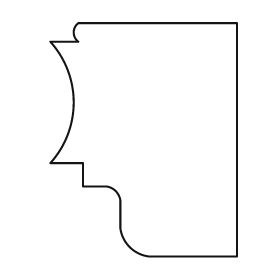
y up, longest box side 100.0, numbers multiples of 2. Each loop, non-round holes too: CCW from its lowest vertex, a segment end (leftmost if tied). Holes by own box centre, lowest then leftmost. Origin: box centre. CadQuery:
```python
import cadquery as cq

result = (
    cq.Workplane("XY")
    .moveTo(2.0, -50.0)
    .lineTo(40.0, -50.0)
    .lineTo(40.0, 50.0)
    .lineTo(-28.0, 50.0)
    .threePointArc((-30.0, 46.0), (-28.0, 42.0))
    .lineTo(-40.0, 42.0)
    .threePointArc((-30.0, 16.0), (-40.0, -10.0))
    .lineTo(-26.0, -10.0)
    .lineTo(-26.0, -20.0)
    .lineTo(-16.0, -20.0)
    .threePointArc((-12.0, -22.0), (-10.0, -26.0))
    .lineTo(-10.0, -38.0)
    .threePointArc((-6.0, -46.0), (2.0, -50.0))
    .close()
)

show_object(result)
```